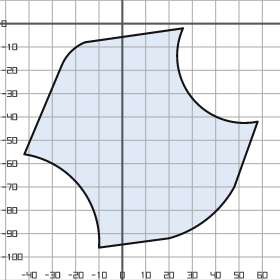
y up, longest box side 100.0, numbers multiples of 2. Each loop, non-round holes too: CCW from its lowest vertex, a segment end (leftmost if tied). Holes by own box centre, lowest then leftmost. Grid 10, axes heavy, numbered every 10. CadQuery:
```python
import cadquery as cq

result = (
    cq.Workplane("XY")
    .moveTo(-10.0, -96.0)
    .lineTo(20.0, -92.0)
    .threePointArc((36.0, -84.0), (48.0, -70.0))
    .lineTo(58.0, -42.0)
    .threePointArc((30.0, -32.0), (26.0, -2.0))
    .lineTo(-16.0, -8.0)
    .threePointArc((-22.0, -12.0), (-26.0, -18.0))
    .lineTo(-42.0, -56.0)
    .threePointArc((-18.0, -70.0), (-10.0, -96.0))
    .close()
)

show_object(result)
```